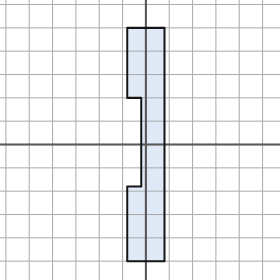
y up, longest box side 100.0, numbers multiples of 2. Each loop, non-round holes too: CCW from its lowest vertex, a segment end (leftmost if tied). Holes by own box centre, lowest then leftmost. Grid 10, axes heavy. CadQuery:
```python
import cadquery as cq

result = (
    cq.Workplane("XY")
    .moveTo(-8.0, -50.0)
    .lineTo(8.0, -50.0)
    .lineTo(8.0, 50.0)
    .lineTo(-8.0, 50.0)
    .lineTo(-8.0, 20.0)
    .lineTo(-2.0, 20.0)
    .lineTo(-2.0, -18.0)
    .lineTo(-8.0, -18.0)
    .close()
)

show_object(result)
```